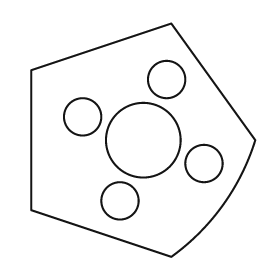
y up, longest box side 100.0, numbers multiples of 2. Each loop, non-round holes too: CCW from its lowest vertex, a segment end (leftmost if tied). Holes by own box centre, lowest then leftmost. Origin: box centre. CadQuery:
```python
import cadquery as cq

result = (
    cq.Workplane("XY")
    .moveTo(12.0, -50.0)
    .threePointArc((34.0, -28.0), (48.0, 0.0))
    .lineTo(12.0, 50.0)
    .lineTo(-48.0, 30.0)
    .lineTo(-48.0, -30.0)
    .close()
    .moveTo(-10.0, -26.0)
    .circle(8.0)
    .moveTo(26.0, -10.0)
    .circle(8.0)
    .moveTo(0.0, 0.0)
    .circle(16.0)
    .moveTo(-26.0, 10.0)
    .circle(8.0)
    .moveTo(10.0, 26.0)
    .circle(8.0)
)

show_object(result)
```